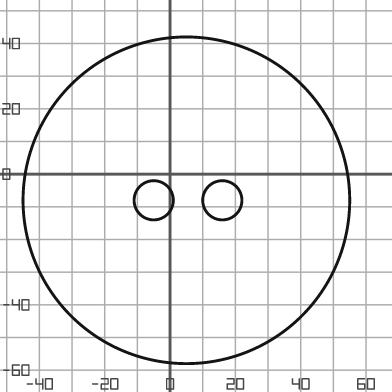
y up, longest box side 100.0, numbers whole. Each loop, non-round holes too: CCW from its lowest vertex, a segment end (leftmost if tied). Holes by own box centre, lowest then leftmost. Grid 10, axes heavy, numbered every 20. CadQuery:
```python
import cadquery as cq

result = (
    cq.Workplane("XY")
    .moveTo(5.0, -8.0)
    .circle(50.0)
    .moveTo(-5.0, -8.0)
    .circle(6.0)
    .moveTo(16.0, -8.0)
    .circle(6.0)
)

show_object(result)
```